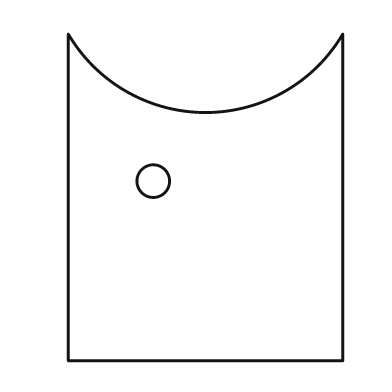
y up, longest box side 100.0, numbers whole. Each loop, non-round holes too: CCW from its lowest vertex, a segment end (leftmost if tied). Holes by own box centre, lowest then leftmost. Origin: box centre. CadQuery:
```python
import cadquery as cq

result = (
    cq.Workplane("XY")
    .moveTo(-42.0, -50.0)
    .lineTo(42.0, -50.0)
    .lineTo(42.0, 50.0)
    .threePointArc((0.0, 26.0), (-42.0, 50.0))
    .close()
    .moveTo(-16.0, 5.0)
    .circle(5.0)
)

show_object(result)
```